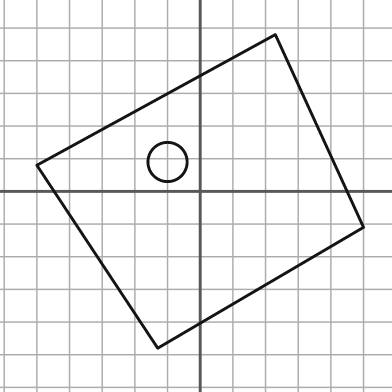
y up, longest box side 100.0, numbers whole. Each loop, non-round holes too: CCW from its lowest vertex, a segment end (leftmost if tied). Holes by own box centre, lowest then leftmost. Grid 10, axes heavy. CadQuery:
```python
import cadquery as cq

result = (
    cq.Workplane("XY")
    .moveTo(-13.0, -48.0)
    .lineTo(50.0, -11.0)
    .lineTo(23.0, 48.0)
    .lineTo(-50.0, 8.0)
    .close()
    .moveTo(-10.0, 9.0)
    .circle(6.0)
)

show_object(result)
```